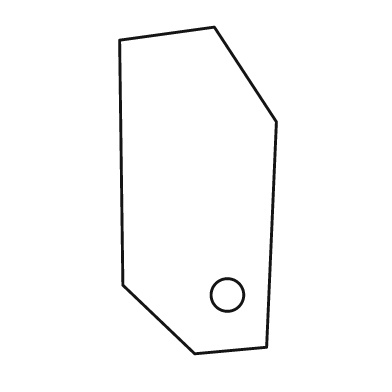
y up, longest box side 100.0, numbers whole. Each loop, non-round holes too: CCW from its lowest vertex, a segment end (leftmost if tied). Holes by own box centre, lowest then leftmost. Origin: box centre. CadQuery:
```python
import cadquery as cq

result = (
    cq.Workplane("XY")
    .moveTo(-1.0, -50.0)
    .lineTo(21.0, -48.0)
    .lineTo(24.0, 21.0)
    .lineTo(5.0, 50.0)
    .lineTo(-24.0, 46.0)
    .lineTo(-23.0, -29.0)
    .close()
    .moveTo(9.0, -32.0)
    .circle(5.0)
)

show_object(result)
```